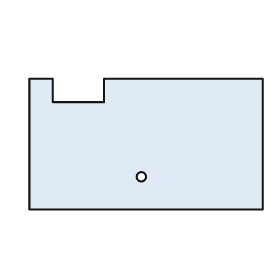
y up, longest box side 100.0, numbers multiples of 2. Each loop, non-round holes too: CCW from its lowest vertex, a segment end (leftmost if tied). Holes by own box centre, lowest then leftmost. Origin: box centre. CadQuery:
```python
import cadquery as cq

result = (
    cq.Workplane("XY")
    .moveTo(-50.0, -28.0)
    .lineTo(50.0, -28.0)
    .lineTo(50.0, 28.0)
    .lineTo(-18.0, 28.0)
    .lineTo(-18.0, 18.0)
    .lineTo(-40.0, 18.0)
    .lineTo(-40.0, 28.0)
    .lineTo(-50.0, 28.0)
    .close()
    .moveTo(-2.0, -14.0)
    .circle(2.0)
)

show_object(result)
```